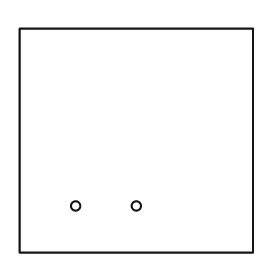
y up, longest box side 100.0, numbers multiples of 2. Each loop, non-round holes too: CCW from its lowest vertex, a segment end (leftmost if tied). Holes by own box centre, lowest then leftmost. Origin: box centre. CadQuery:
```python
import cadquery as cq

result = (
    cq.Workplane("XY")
    .moveTo(-50.0, -48.0)
    .lineTo(50.0, -48.0)
    .lineTo(50.0, 48.0)
    .lineTo(-50.0, 48.0)
    .close()
    .moveTo(-26.0, -28.0)
    .circle(2.0)
    .moveTo(0.0, -28.0)
    .circle(2.0)
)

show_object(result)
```